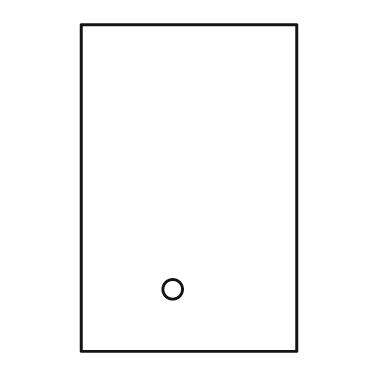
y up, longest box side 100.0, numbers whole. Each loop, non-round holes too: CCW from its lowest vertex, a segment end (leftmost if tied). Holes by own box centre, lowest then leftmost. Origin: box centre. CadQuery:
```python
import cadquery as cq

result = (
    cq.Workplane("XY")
    .moveTo(-33.0, -50.0)
    .lineTo(33.0, -50.0)
    .lineTo(33.0, 50.0)
    .lineTo(-33.0, 50.0)
    .close()
    .moveTo(-5.0, -31.0)
    .circle(3.0)
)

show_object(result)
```